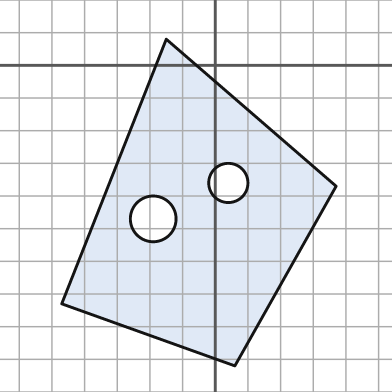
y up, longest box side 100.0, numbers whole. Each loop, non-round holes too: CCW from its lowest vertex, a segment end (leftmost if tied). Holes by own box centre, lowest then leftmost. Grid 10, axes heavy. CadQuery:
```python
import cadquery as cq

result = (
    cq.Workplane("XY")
    .moveTo(6.0, -92.0)
    .lineTo(37.0, -37.0)
    .lineTo(-15.0, 8.0)
    .lineTo(-47.0, -73.0)
    .close()
    .moveTo(-19.0, -47.0)
    .circle(7.0)
    .moveTo(4.0, -36.0)
    .circle(6.0)
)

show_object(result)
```